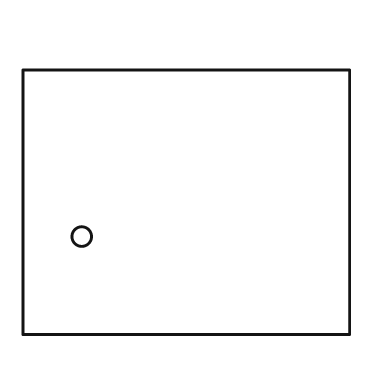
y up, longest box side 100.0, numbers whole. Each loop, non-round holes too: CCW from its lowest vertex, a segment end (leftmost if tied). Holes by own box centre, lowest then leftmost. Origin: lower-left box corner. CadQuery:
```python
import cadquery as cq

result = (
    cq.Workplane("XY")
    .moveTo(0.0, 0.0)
    .lineTo(100.0, 0.0)
    .lineTo(100.0, 81.0)
    .lineTo(0.0, 81.0)
    .close()
    .moveTo(18.0, 30.0)
    .circle(3.0)
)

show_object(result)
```